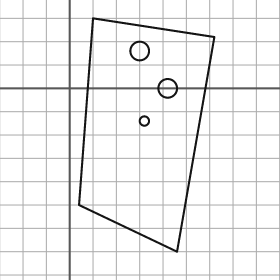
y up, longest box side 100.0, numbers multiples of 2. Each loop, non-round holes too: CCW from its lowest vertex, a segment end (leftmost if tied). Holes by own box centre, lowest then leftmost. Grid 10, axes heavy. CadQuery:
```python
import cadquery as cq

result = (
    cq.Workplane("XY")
    .moveTo(46.0, -70.0)
    .lineTo(62.0, 22.0)
    .lineTo(10.0, 30.0)
    .lineTo(4.0, -50.0)
    .close()
    .moveTo(32.0, -14.0)
    .circle(2.0)
    .moveTo(42.0, 0.0)
    .circle(4.0)
    .moveTo(30.0, 16.0)
    .circle(4.0)
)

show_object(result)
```